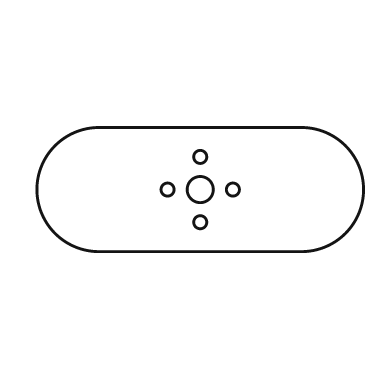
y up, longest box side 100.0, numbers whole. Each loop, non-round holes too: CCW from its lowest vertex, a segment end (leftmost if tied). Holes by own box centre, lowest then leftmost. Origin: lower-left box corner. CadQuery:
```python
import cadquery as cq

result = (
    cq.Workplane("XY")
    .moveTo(19.0, 0.0)
    .lineTo(81.0, 0.0)
    .threePointArc((100.0, 19.0), (81.0, 38.0))
    .lineTo(19.0, 38.0)
    .threePointArc((0.0, 19.0), (19.0, 0.0))
    .close()
    .moveTo(50.0, 9.0)
    .circle(2.0)
    .moveTo(40.0, 19.0)
    .circle(2.0)
    .moveTo(50.0, 19.0)
    .circle(4.0)
    .moveTo(60.0, 19.0)
    .circle(2.0)
    .moveTo(50.0, 29.0)
    .circle(2.0)
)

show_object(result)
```